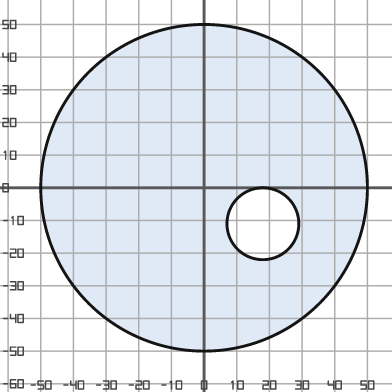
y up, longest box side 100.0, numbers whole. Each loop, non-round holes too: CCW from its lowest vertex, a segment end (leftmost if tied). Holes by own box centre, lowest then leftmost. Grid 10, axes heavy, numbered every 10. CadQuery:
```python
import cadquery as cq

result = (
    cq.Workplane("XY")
    .moveTo(0.0, 0.0)
    .circle(50.0)
    .moveTo(18.0, -11.0)
    .circle(11.0)
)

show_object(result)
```